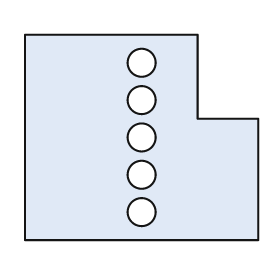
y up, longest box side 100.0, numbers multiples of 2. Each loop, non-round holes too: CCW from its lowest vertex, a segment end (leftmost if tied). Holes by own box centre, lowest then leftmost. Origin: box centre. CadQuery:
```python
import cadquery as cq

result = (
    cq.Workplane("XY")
    .moveTo(-50.0, -44.0)
    .lineTo(50.0, -44.0)
    .lineTo(50.0, 8.0)
    .lineTo(24.0, 8.0)
    .lineTo(24.0, 44.0)
    .lineTo(-50.0, 44.0)
    .close()
    .moveTo(0.0, -32.0)
    .circle(6.0)
    .moveTo(0.0, -16.0)
    .circle(6.0)
    .moveTo(0.0, 0.0)
    .circle(6.0)
    .moveTo(0.0, 16.0)
    .circle(6.0)
    .moveTo(0.0, 32.0)
    .circle(6.0)
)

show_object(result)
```